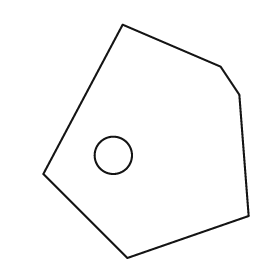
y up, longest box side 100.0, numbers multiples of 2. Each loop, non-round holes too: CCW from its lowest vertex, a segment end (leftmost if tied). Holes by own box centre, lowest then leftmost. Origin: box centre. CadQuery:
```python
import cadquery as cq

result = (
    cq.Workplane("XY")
    .moveTo(-8.0, -50.0)
    .lineTo(44.0, -32.0)
    .lineTo(40.0, 20.0)
    .lineTo(32.0, 32.0)
    .lineTo(-10.0, 50.0)
    .lineTo(-44.0, -14.0)
    .close()
    .moveTo(-14.0, -6.0)
    .circle(8.0)
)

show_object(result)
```